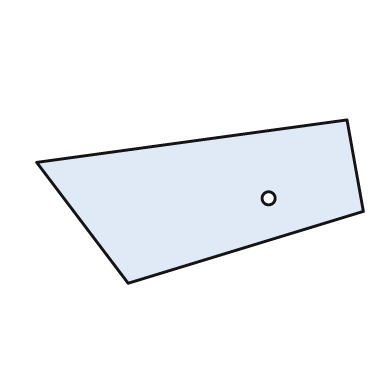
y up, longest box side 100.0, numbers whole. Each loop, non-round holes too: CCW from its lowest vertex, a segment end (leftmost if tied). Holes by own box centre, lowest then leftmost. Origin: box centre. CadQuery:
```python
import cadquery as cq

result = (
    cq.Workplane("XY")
    .moveTo(-22.0, -25.0)
    .lineTo(50.0, -3.0)
    .lineTo(45.0, 25.0)
    .lineTo(-50.0, 12.0)
    .close()
    .moveTo(21.0, 1.0)
    .circle(2.0)
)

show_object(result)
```